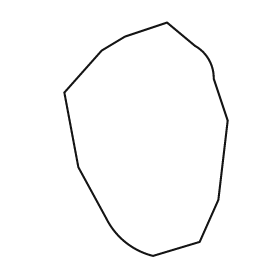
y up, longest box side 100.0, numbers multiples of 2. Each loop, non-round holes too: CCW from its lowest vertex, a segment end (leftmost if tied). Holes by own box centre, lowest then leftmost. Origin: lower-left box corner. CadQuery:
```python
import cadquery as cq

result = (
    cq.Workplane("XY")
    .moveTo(38.0, 0.0)
    .lineTo(58.0, 6.0)
    .lineTo(66.0, 24.0)
    .lineTo(70.0, 58.0)
    .lineTo(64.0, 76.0)
    .threePointArc((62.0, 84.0), (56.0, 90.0))
    .lineTo(44.0, 100.0)
    .lineTo(26.0, 94.0)
    .lineTo(16.0, 88.0)
    .lineTo(0.0, 70.0)
    .lineTo(6.0, 38.0)
    .lineTo(18.0, 16.0)
    .threePointArc((26.0, 6.0), (38.0, 0.0))
    .close()
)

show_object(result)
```